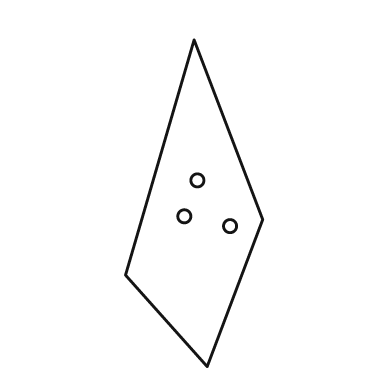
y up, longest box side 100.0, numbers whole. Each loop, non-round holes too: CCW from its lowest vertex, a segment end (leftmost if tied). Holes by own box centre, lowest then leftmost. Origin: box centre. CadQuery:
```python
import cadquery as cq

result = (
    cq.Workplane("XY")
    .moveTo(4.0, -50.0)
    .lineTo(21.0, -5.0)
    .lineTo(0.0, 50.0)
    .lineTo(-21.0, -22.0)
    .close()
    .moveTo(11.0, -7.0)
    .circle(2.0)
    .moveTo(-3.0, -4.0)
    .circle(2.0)
    .moveTo(1.0, 7.0)
    .circle(2.0)
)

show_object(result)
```